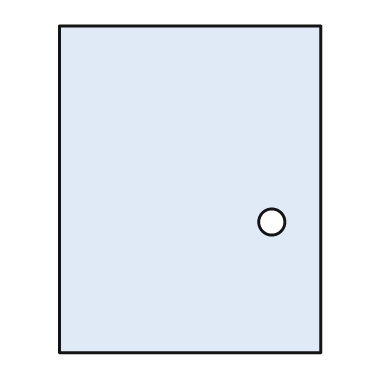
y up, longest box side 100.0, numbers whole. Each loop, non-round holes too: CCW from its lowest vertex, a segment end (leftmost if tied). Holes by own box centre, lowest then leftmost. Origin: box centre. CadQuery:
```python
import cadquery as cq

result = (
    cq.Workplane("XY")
    .moveTo(-40.0, -50.0)
    .lineTo(40.0, -50.0)
    .lineTo(40.0, 50.0)
    .lineTo(-40.0, 50.0)
    .close()
    .moveTo(25.0, -10.0)
    .circle(4.0)
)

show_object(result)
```